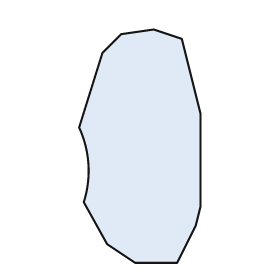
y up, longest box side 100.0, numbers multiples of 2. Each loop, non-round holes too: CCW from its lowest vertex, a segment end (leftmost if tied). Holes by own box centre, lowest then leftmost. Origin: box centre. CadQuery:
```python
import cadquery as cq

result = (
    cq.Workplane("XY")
    .moveTo(-2.0, -50.0)
    .lineTo(16.0, -50.0)
    .lineTo(24.0, -34.0)
    .lineTo(26.0, -26.0)
    .lineTo(26.0, 14.0)
    .lineTo(18.0, 46.0)
    .lineTo(6.0, 50.0)
    .lineTo(-8.0, 48.0)
    .lineTo(-16.0, 40.0)
    .lineTo(-26.0, 8.0)
    .threePointArc((-22.0, -8.0), (-24.0, -24.0))
    .lineTo(-14.0, -42.0)
    .close()
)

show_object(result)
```